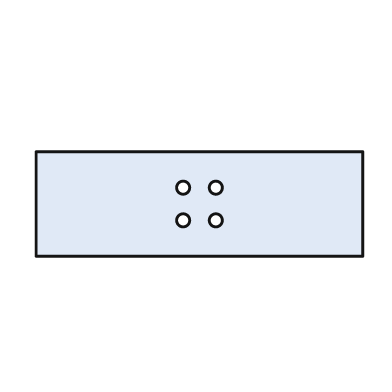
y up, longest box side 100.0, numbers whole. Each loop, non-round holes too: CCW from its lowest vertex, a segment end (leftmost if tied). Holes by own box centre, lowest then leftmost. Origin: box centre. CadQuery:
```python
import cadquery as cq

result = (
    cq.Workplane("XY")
    .moveTo(-50.0, -16.0)
    .lineTo(50.0, -16.0)
    .lineTo(50.0, 16.0)
    .lineTo(-50.0, 16.0)
    .close()
    .moveTo(-5.0, -5.0)
    .circle(2.0)
    .moveTo(5.0, -5.0)
    .circle(2.0)
    .moveTo(-5.0, 5.0)
    .circle(2.0)
    .moveTo(5.0, 5.0)
    .circle(2.0)
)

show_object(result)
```